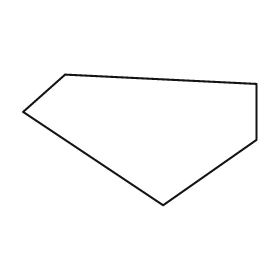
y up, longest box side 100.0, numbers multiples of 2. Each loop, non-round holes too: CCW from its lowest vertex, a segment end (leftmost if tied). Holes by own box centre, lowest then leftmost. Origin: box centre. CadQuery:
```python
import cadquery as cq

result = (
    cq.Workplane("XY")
    .moveTo(10.0, -28.0)
    .lineTo(50.0, 0.0)
    .lineTo(50.0, 24.0)
    .lineTo(-32.0, 28.0)
    .lineTo(-50.0, 12.0)
    .close()
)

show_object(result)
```